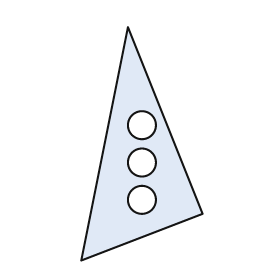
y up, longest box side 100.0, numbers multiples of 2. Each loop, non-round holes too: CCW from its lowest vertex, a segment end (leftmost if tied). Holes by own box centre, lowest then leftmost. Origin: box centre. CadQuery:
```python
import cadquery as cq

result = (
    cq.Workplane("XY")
    .moveTo(-26.0, -50.0)
    .lineTo(26.0, -30.0)
    .lineTo(-6.0, 50.0)
    .close()
    .moveTo(0.0, -24.0)
    .circle(6.0)
    .moveTo(0.0, -8.0)
    .circle(6.0)
    .moveTo(0.0, 8.0)
    .circle(6.0)
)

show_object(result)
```